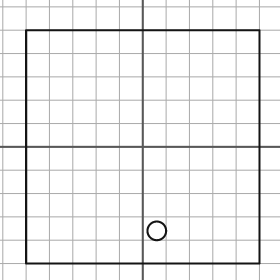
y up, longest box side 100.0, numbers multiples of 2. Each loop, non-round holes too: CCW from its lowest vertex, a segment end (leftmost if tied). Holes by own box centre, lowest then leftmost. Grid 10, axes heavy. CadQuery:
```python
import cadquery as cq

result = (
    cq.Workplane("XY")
    .moveTo(-50.0, -50.0)
    .lineTo(50.0, -50.0)
    .lineTo(50.0, 50.0)
    .lineTo(-50.0, 50.0)
    .close()
    .moveTo(6.0, -36.0)
    .circle(4.0)
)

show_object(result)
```